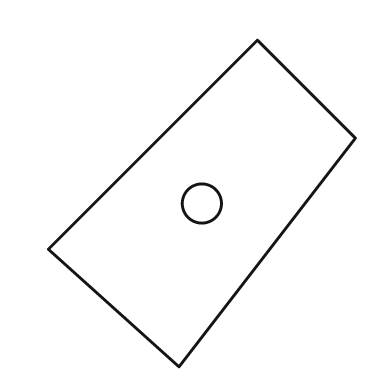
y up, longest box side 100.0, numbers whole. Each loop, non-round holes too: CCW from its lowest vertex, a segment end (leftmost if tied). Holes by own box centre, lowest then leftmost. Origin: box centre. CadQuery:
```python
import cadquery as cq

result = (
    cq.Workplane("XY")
    .moveTo(-7.0, -50.0)
    .lineTo(47.0, 20.0)
    .lineTo(17.0, 50.0)
    .lineTo(-47.0, -14.0)
    .close()
    .moveTo(0.0, 0.0)
    .circle(6.0)
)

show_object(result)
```